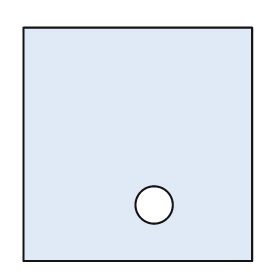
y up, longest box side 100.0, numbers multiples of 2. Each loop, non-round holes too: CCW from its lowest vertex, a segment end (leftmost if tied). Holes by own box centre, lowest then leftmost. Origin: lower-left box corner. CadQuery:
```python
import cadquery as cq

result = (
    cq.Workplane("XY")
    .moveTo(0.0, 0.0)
    .lineTo(98.0, 0.0)
    .lineTo(98.0, 100.0)
    .lineTo(0.0, 100.0)
    .close()
    .moveTo(56.0, 24.0)
    .circle(8.0)
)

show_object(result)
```